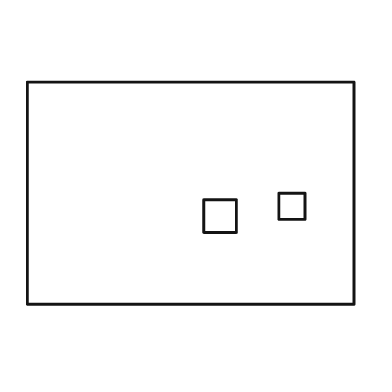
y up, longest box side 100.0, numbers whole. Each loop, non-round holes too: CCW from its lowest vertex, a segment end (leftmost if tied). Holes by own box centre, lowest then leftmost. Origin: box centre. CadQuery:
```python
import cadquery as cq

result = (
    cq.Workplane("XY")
    .moveTo(-50.0, -34.0)
    .lineTo(50.0, -34.0)
    .lineTo(50.0, 34.0)
    .lineTo(-50.0, 34.0)
    .close()
    .moveTo(4.0, -12.0)
    .lineTo(14.0, -12.0)
    .lineTo(14.0, -2.0)
    .lineTo(4.0, -2.0)
    .close()
    .moveTo(27.0, -8.0)
    .lineTo(35.0, -8.0)
    .lineTo(35.0, 0.0)
    .lineTo(27.0, 0.0)
    .close()
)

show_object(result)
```